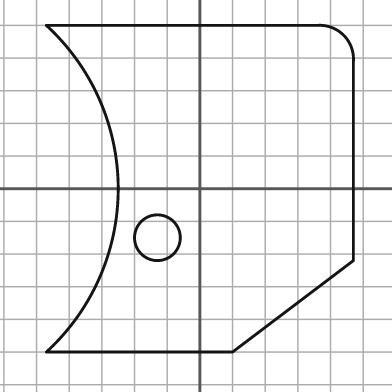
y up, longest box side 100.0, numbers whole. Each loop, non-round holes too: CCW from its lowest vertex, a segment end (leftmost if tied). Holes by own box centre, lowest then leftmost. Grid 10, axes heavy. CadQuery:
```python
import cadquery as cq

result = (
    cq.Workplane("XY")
    .moveTo(-47.0, -50.0)
    .lineTo(10.0, -50.0)
    .lineTo(47.0, -22.0)
    .lineTo(47.0, 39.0)
    .threePointArc((44.0, 47.0), (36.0, 50.0))
    .lineTo(-47.0, 50.0)
    .threePointArc((-25.0, 0.0), (-47.0, -50.0))
    .close()
    .moveTo(-13.0, -15.0)
    .circle(7.0)
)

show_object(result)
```